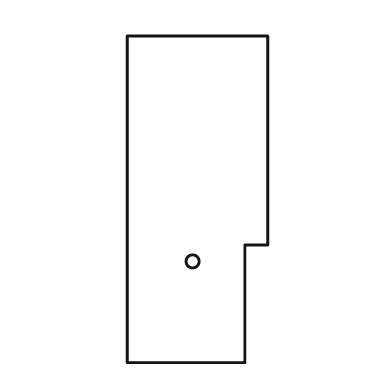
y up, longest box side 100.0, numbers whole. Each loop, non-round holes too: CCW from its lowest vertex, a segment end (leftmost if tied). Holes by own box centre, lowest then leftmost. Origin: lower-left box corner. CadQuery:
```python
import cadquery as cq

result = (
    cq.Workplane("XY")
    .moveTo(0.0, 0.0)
    .lineTo(36.0, 0.0)
    .lineTo(36.0, 36.0)
    .lineTo(43.0, 36.0)
    .lineTo(43.0, 100.0)
    .lineTo(0.0, 100.0)
    .close()
    .moveTo(20.0, 31.0)
    .circle(2.0)
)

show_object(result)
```